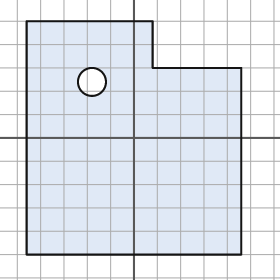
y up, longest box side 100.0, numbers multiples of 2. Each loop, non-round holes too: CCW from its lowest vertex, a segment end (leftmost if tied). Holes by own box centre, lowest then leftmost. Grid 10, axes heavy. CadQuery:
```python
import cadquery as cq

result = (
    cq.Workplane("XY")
    .moveTo(-46.0, -50.0)
    .lineTo(46.0, -50.0)
    .lineTo(46.0, 30.0)
    .lineTo(8.0, 30.0)
    .lineTo(8.0, 50.0)
    .lineTo(-46.0, 50.0)
    .close()
    .moveTo(-18.0, 24.0)
    .circle(6.0)
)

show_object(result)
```